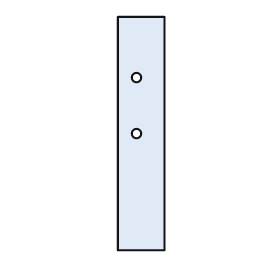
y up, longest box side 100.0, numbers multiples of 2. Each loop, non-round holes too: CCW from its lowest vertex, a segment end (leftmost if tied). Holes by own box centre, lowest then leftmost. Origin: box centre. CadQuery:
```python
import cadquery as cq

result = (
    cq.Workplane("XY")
    .moveTo(-10.0, -50.0)
    .lineTo(10.0, -50.0)
    .lineTo(10.0, 50.0)
    .lineTo(-10.0, 50.0)
    .close()
    .moveTo(-2.0, 0.0)
    .circle(2.0)
    .moveTo(-2.0, 24.0)
    .circle(2.0)
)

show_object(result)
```